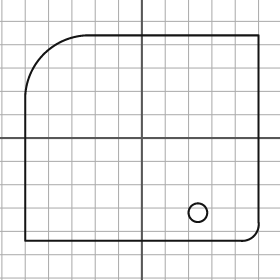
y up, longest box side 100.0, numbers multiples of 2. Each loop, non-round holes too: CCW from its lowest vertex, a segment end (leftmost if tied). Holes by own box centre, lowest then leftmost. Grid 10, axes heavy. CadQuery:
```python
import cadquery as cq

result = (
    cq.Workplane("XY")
    .moveTo(-50.0, -44.0)
    .lineTo(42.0, -44.0)
    .threePointArc((48.0, -42.0), (50.0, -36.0))
    .lineTo(50.0, 44.0)
    .lineTo(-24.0, 44.0)
    .threePointArc((-42.0, 36.0), (-50.0, 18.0))
    .close()
    .moveTo(24.0, -32.0)
    .circle(4.0)
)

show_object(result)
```